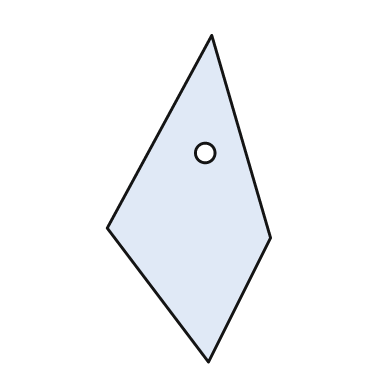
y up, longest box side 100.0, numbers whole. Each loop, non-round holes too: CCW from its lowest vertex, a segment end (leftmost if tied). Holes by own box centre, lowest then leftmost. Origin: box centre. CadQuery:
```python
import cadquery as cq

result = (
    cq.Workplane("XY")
    .moveTo(6.0, -50.0)
    .lineTo(25.0, -12.0)
    .lineTo(7.0, 50.0)
    .lineTo(-25.0, -9.0)
    .close()
    .moveTo(5.0, 14.0)
    .circle(3.0)
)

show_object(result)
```